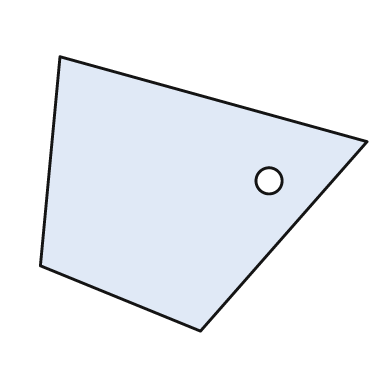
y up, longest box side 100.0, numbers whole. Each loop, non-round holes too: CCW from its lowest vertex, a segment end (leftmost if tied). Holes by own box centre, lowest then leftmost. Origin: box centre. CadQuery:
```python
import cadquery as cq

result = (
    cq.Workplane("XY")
    .moveTo(-1.0, -42.0)
    .lineTo(50.0, 16.0)
    .lineTo(-44.0, 42.0)
    .lineTo(-50.0, -22.0)
    .close()
    .moveTo(20.0, 4.0)
    .circle(4.0)
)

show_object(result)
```